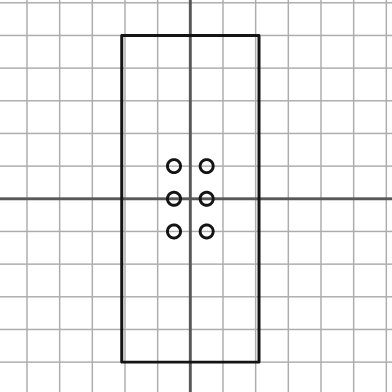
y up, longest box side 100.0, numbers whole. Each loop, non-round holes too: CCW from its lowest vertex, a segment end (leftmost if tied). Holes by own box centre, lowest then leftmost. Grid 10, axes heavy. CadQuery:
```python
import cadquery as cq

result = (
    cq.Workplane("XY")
    .moveTo(-21.0, -50.0)
    .lineTo(21.0, -50.0)
    .lineTo(21.0, 50.0)
    .lineTo(-21.0, 50.0)
    .close()
    .moveTo(-5.0, -10.0)
    .circle(2.0)
    .moveTo(5.0, -10.0)
    .circle(2.0)
    .moveTo(-5.0, 0.0)
    .circle(2.0)
    .moveTo(5.0, 0.0)
    .circle(2.0)
    .moveTo(-5.0, 10.0)
    .circle(2.0)
    .moveTo(5.0, 10.0)
    .circle(2.0)
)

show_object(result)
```